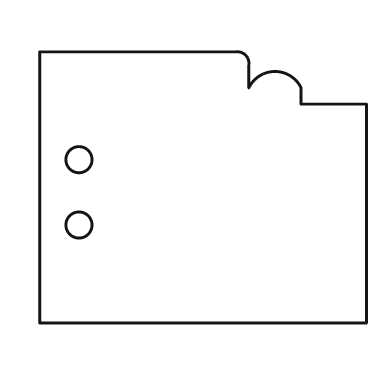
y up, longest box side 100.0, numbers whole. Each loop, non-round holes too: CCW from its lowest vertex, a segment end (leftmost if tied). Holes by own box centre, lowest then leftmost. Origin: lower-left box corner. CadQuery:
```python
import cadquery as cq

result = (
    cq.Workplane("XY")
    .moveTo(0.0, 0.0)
    .lineTo(100.0, 0.0)
    .lineTo(100.0, 67.0)
    .lineTo(80.0, 67.0)
    .lineTo(80.0, 72.0)
    .threePointArc((72.0, 77.0), (64.0, 72.0))
    .lineTo(64.0, 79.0)
    .threePointArc((63.0, 82.0), (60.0, 83.0))
    .lineTo(0.0, 83.0)
    .close()
    .moveTo(12.0, 30.0)
    .circle(4.0)
    .moveTo(12.0, 50.0)
    .circle(4.0)
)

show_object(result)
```